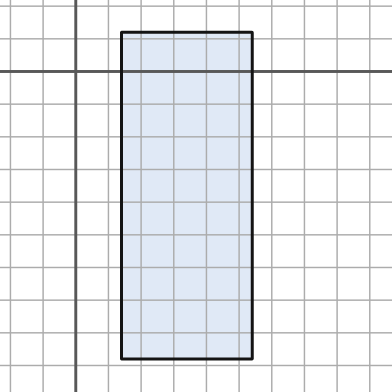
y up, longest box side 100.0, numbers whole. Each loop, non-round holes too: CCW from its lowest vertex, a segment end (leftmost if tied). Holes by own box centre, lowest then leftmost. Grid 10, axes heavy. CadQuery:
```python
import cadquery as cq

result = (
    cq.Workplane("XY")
    .moveTo(14.0, -88.0)
    .lineTo(54.0, -88.0)
    .lineTo(54.0, 12.0)
    .lineTo(14.0, 12.0)
    .close()
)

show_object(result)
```